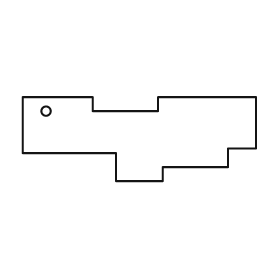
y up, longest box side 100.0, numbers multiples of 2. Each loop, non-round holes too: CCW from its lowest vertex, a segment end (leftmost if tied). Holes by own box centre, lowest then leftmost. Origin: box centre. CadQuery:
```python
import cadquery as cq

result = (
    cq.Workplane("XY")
    .moveTo(-10.0, -18.0)
    .lineTo(10.0, -18.0)
    .lineTo(10.0, -12.0)
    .lineTo(38.0, -12.0)
    .lineTo(38.0, -4.0)
    .lineTo(50.0, -4.0)
    .lineTo(50.0, 18.0)
    .lineTo(8.0, 18.0)
    .lineTo(8.0, 12.0)
    .lineTo(-20.0, 12.0)
    .lineTo(-20.0, 18.0)
    .lineTo(-50.0, 18.0)
    .lineTo(-50.0, -6.0)
    .lineTo(-10.0, -6.0)
    .close()
    .moveTo(-40.0, 12.0)
    .circle(2.0)
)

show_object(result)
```